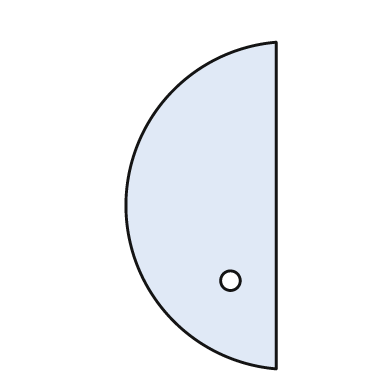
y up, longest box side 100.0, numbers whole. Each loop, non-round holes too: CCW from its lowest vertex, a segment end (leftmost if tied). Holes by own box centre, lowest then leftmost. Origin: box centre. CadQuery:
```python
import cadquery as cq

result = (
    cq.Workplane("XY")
    .moveTo(23.0, -50.0)
    .lineTo(23.0, 50.0)
    .threePointArc((-23.0, 0.0), (23.0, -50.0))
    .close()
    .moveTo(9.0, -23.0)
    .circle(3.0)
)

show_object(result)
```